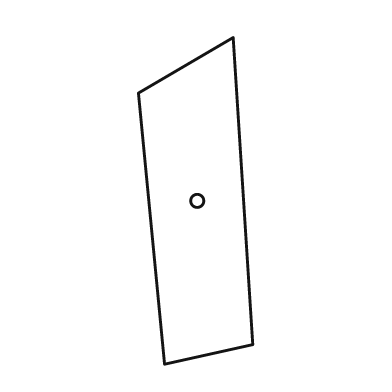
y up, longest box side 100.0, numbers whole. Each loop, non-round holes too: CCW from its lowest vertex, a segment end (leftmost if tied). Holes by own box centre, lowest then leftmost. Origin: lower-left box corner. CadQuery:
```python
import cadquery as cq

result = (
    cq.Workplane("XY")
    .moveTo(8.0, 0.0)
    .lineTo(35.0, 6.0)
    .lineTo(29.0, 100.0)
    .lineTo(0.0, 83.0)
    .close()
    .moveTo(18.0, 50.0)
    .circle(2.0)
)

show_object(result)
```